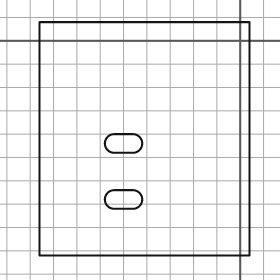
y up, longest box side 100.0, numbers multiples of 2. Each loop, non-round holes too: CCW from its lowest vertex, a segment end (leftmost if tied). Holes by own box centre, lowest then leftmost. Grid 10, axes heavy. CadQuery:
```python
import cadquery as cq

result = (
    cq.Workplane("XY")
    .moveTo(-86.0, -92.0)
    .lineTo(4.0, -92.0)
    .lineTo(4.0, 8.0)
    .lineTo(-86.0, 8.0)
    .close()
    .moveTo(-54.0, -72.0)
    .lineTo(-46.0, -72.0)
    .threePointArc((-42.0, -68.0), (-46.0, -64.0))
    .lineTo(-54.0, -64.0)
    .threePointArc((-58.0, -68.0), (-54.0, -72.0))
    .close()
    .moveTo(-54.0, -48.0)
    .lineTo(-46.0, -48.0)
    .threePointArc((-42.0, -44.0), (-46.0, -40.0))
    .lineTo(-54.0, -40.0)
    .threePointArc((-58.0, -44.0), (-54.0, -48.0))
    .close()
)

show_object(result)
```